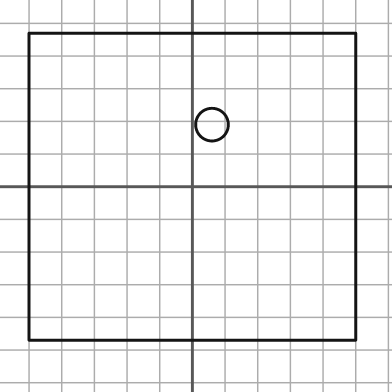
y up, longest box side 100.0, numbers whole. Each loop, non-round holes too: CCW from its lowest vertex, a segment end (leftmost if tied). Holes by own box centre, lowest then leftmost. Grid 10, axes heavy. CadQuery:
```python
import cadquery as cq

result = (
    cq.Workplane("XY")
    .moveTo(-50.0, -47.0)
    .lineTo(50.0, -47.0)
    .lineTo(50.0, 47.0)
    .lineTo(-50.0, 47.0)
    .close()
    .moveTo(6.0, 19.0)
    .circle(5.0)
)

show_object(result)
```